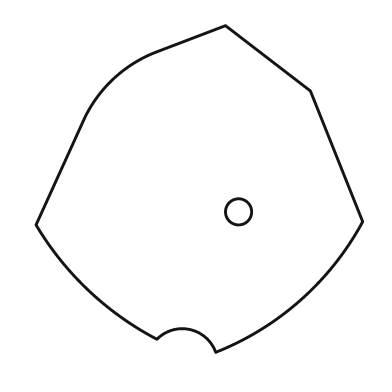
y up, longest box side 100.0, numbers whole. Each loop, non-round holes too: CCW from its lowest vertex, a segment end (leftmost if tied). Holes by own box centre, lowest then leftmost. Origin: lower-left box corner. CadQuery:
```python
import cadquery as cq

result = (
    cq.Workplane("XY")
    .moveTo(55.0, 0.0)
    .threePointArc((81.0, 16.0), (100.0, 40.0))
    .lineTo(84.0, 80.0)
    .lineTo(58.0, 100.0)
    .lineTo(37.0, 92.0)
    .threePointArc((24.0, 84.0), (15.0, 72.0))
    .lineTo(0.0, 39.0)
    .threePointArc((16.0, 19.0), (37.0, 4.0))
    .threePointArc((47.0, 7.0), (55.0, 0.0))
    .close()
    .moveTo(62.0, 43.0)
    .circle(4.0)
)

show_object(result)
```